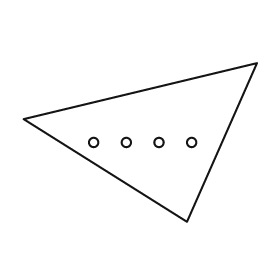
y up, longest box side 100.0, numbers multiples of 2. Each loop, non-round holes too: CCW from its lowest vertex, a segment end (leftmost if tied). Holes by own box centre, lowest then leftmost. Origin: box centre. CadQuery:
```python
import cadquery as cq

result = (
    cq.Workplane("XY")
    .moveTo(20.0, -34.0)
    .lineTo(50.0, 34.0)
    .lineTo(-50.0, 10.0)
    .close()
    .moveTo(-20.0, 0.0)
    .circle(2.0)
    .moveTo(-6.0, 0.0)
    .circle(2.0)
    .moveTo(8.0, 0.0)
    .circle(2.0)
    .moveTo(22.0, 0.0)
    .circle(2.0)
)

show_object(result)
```